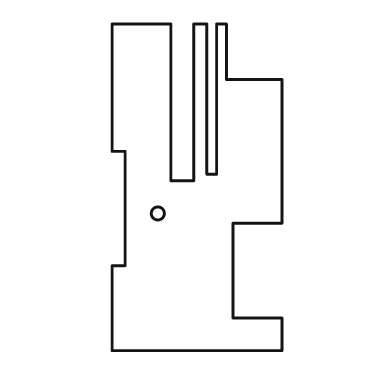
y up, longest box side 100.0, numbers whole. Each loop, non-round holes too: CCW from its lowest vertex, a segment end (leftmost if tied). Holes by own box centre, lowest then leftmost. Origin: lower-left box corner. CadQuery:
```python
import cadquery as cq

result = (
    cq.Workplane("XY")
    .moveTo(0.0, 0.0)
    .lineTo(52.0, 0.0)
    .lineTo(52.0, 10.0)
    .lineTo(37.0, 10.0)
    .lineTo(37.0, 39.0)
    .lineTo(52.0, 39.0)
    .lineTo(52.0, 83.0)
    .lineTo(35.0, 83.0)
    .lineTo(35.0, 100.0)
    .lineTo(32.0, 100.0)
    .lineTo(32.0, 54.0)
    .lineTo(29.0, 54.0)
    .lineTo(29.0, 100.0)
    .lineTo(25.0, 100.0)
    .lineTo(25.0, 52.0)
    .lineTo(18.0, 52.0)
    .lineTo(18.0, 100.0)
    .lineTo(0.0, 100.0)
    .lineTo(0.0, 61.0)
    .lineTo(4.0, 61.0)
    .lineTo(4.0, 26.0)
    .lineTo(0.0, 26.0)
    .close()
    .moveTo(14.0, 42.0)
    .circle(2.0)
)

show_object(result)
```